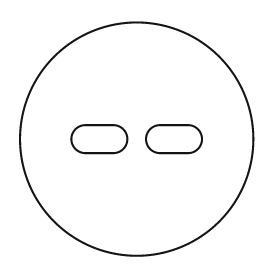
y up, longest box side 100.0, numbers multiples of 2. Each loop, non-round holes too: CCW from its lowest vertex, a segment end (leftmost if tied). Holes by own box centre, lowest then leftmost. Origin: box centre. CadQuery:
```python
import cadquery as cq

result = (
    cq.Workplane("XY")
    .moveTo(0.0, 0.0)
    .circle(50.0)
    .moveTo(-22.0, -6.0)
    .lineTo(-10.0, -6.0)
    .threePointArc((-4.0, 0.0), (-10.0, 6.0))
    .lineTo(-22.0, 6.0)
    .threePointArc((-28.0, 0.0), (-22.0, -6.0))
    .close()
    .moveTo(10.0, -6.0)
    .lineTo(22.0, -6.0)
    .threePointArc((28.0, 0.0), (22.0, 6.0))
    .lineTo(10.0, 6.0)
    .threePointArc((4.0, 0.0), (10.0, -6.0))
    .close()
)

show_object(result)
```